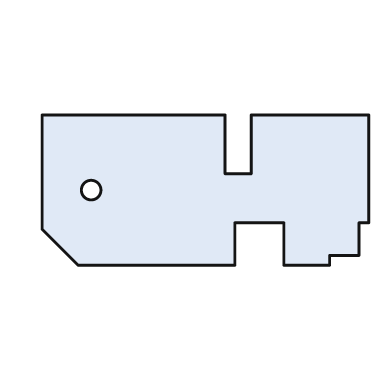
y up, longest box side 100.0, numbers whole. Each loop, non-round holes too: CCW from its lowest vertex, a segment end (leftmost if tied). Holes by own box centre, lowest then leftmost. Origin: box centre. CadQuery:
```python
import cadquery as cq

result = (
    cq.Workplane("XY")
    .moveTo(-39.0, -23.0)
    .lineTo(9.0, -23.0)
    .lineTo(9.0, -10.0)
    .lineTo(24.0, -10.0)
    .lineTo(24.0, -23.0)
    .lineTo(38.0, -23.0)
    .lineTo(38.0, -20.0)
    .lineTo(47.0, -20.0)
    .lineTo(47.0, -10.0)
    .lineTo(50.0, -10.0)
    .lineTo(50.0, 23.0)
    .lineTo(14.0, 23.0)
    .lineTo(14.0, 5.0)
    .lineTo(6.0, 5.0)
    .lineTo(6.0, 23.0)
    .lineTo(-50.0, 23.0)
    .lineTo(-50.0, -12.0)
    .close()
    .moveTo(-35.0, 0.0)
    .circle(3.0)
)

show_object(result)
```